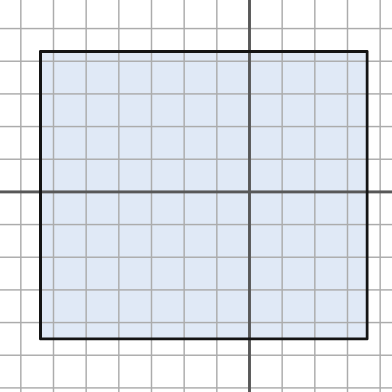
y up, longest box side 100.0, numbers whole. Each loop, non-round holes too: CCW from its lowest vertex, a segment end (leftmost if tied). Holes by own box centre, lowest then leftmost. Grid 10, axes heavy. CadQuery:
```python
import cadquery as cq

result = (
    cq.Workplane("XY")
    .moveTo(-64.0, -45.0)
    .lineTo(36.0, -45.0)
    .lineTo(36.0, 43.0)
    .lineTo(-64.0, 43.0)
    .close()
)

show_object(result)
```